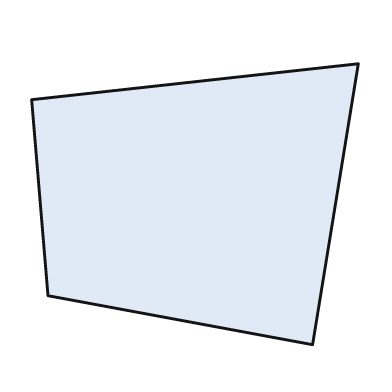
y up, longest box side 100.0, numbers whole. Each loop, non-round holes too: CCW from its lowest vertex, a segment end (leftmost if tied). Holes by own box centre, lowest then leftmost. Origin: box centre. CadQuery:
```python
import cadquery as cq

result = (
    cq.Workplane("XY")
    .moveTo(36.0, -43.0)
    .lineTo(50.0, 43.0)
    .lineTo(-50.0, 32.0)
    .lineTo(-45.0, -28.0)
    .close()
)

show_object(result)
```